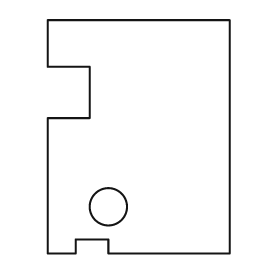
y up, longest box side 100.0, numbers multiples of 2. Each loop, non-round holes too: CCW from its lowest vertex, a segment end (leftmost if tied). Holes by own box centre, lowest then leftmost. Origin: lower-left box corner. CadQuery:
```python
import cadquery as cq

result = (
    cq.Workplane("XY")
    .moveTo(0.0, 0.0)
    .lineTo(12.0, 0.0)
    .lineTo(12.0, 6.0)
    .lineTo(26.0, 6.0)
    .lineTo(26.0, 0.0)
    .lineTo(78.0, 0.0)
    .lineTo(78.0, 100.0)
    .lineTo(0.0, 100.0)
    .lineTo(0.0, 80.0)
    .lineTo(18.0, 80.0)
    .lineTo(18.0, 58.0)
    .lineTo(0.0, 58.0)
    .close()
    .moveTo(26.0, 20.0)
    .circle(8.0)
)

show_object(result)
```